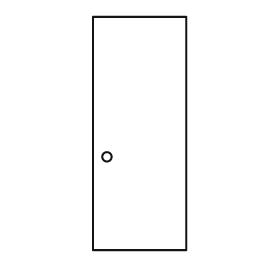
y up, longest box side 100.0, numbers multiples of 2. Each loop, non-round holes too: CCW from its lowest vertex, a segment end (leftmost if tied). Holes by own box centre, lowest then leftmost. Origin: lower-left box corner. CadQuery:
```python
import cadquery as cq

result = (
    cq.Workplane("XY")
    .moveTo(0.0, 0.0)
    .lineTo(40.0, 0.0)
    .lineTo(40.0, 100.0)
    .lineTo(0.0, 100.0)
    .close()
    .moveTo(6.0, 40.0)
    .circle(2.0)
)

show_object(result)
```